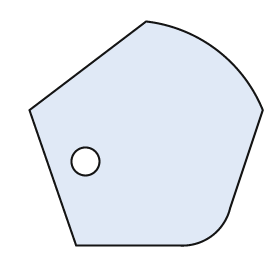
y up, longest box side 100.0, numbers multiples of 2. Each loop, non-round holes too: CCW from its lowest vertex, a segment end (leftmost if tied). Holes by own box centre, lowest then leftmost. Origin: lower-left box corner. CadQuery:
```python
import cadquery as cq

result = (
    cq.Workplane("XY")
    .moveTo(20.0, 0.0)
    .lineTo(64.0, 0.0)
    .threePointArc((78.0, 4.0), (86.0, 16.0))
    .lineTo(100.0, 58.0)
    .threePointArc((80.0, 84.0), (50.0, 96.0))
    .lineTo(0.0, 58.0)
    .close()
    .moveTo(24.0, 36.0)
    .circle(6.0)
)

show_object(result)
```